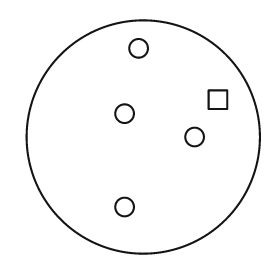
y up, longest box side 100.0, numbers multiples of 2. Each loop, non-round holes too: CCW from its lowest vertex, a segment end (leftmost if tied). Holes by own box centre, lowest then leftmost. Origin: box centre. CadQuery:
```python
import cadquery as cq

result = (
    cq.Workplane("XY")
    .moveTo(0.0, 0.0)
    .circle(50.0)
    .moveTo(-8.0, -30.0)
    .circle(4.0)
    .moveTo(22.0, 0.0)
    .circle(4.0)
    .moveTo(-8.0, 10.0)
    .circle(4.0)
    .moveTo(28.0, 12.0)
    .lineTo(36.0, 12.0)
    .lineTo(36.0, 20.0)
    .lineTo(28.0, 20.0)
    .close()
    .moveTo(-2.0, 38.0)
    .circle(4.0)
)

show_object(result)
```